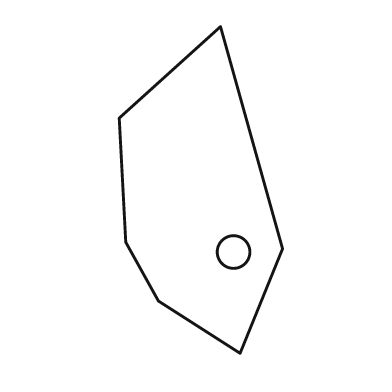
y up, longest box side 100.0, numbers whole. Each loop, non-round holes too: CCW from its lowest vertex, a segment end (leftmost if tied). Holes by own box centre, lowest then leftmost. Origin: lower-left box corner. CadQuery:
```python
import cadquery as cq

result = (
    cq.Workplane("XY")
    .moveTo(37.0, 0.0)
    .lineTo(50.0, 32.0)
    .lineTo(31.0, 100.0)
    .lineTo(0.0, 72.0)
    .lineTo(2.0, 34.0)
    .lineTo(12.0, 16.0)
    .close()
    .moveTo(35.0, 31.0)
    .circle(5.0)
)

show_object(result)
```